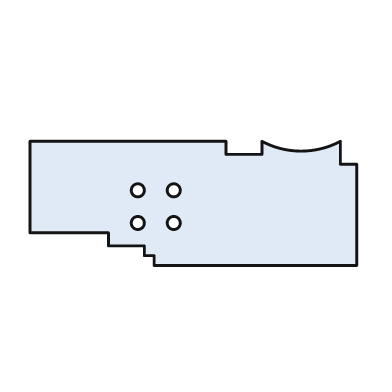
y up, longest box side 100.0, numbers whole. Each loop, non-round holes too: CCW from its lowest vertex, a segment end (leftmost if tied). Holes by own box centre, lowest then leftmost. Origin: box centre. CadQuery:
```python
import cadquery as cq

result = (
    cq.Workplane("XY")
    .moveTo(-12.0, -19.0)
    .lineTo(50.0, -19.0)
    .lineTo(50.0, 12.0)
    .lineTo(45.0, 12.0)
    .lineTo(45.0, 19.0)
    .threePointArc((33.0, 16.0), (21.0, 19.0))
    .lineTo(21.0, 15.0)
    .lineTo(10.0, 15.0)
    .lineTo(10.0, 19.0)
    .lineTo(-50.0, 19.0)
    .lineTo(-50.0, -9.0)
    .lineTo(-26.0, -9.0)
    .lineTo(-26.0, -13.0)
    .lineTo(-15.0, -13.0)
    .lineTo(-15.0, -16.0)
    .lineTo(-12.0, -16.0)
    .close()
    .moveTo(-17.0, -6.0)
    .circle(2.0)
    .moveTo(-6.0, -6.0)
    .circle(2.0)
    .moveTo(-17.0, 4.0)
    .circle(2.0)
    .moveTo(-6.0, 4.0)
    .circle(2.0)
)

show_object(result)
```